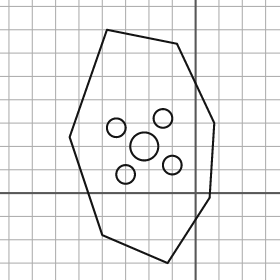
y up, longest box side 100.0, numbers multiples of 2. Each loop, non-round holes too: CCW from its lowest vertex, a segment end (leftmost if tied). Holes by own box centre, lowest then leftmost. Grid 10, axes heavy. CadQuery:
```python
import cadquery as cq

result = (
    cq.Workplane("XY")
    .moveTo(-12.0, -30.0)
    .lineTo(6.0, -2.0)
    .lineTo(8.0, 30.0)
    .lineTo(-8.0, 64.0)
    .lineTo(-38.0, 70.0)
    .lineTo(-54.0, 24.0)
    .lineTo(-40.0, -18.0)
    .close()
    .moveTo(-30.0, 8.0)
    .circle(4.0)
    .moveTo(-10.0, 12.0)
    .circle(4.0)
    .moveTo(-22.0, 20.0)
    .circle(6.0)
    .moveTo(-34.0, 28.0)
    .circle(4.0)
    .moveTo(-14.0, 32.0)
    .circle(4.0)
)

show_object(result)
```